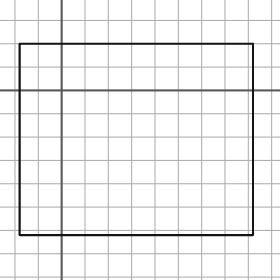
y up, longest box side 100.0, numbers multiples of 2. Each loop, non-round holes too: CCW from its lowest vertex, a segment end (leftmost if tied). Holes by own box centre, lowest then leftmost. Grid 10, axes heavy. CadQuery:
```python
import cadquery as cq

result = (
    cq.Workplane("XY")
    .moveTo(-18.0, -62.0)
    .lineTo(82.0, -62.0)
    .lineTo(82.0, 20.0)
    .lineTo(-18.0, 20.0)
    .close()
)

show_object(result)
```